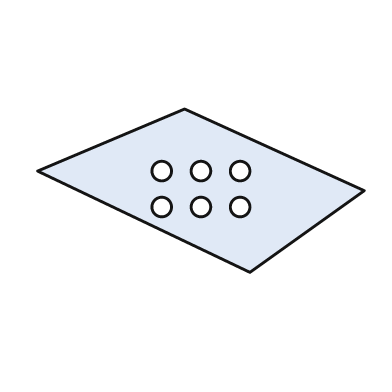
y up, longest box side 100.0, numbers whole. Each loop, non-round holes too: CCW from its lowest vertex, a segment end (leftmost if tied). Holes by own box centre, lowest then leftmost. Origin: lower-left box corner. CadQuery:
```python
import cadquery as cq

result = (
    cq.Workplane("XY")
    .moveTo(65.0, 0.0)
    .lineTo(100.0, 25.0)
    .lineTo(45.0, 50.0)
    .lineTo(0.0, 31.0)
    .close()
    .moveTo(38.0, 20.0)
    .circle(3.0)
    .moveTo(50.0, 20.0)
    .circle(3.0)
    .moveTo(62.0, 20.0)
    .circle(3.0)
    .moveTo(38.0, 31.0)
    .circle(3.0)
    .moveTo(50.0, 31.0)
    .circle(3.0)
    .moveTo(62.0, 31.0)
    .circle(3.0)
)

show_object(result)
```